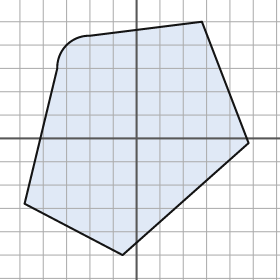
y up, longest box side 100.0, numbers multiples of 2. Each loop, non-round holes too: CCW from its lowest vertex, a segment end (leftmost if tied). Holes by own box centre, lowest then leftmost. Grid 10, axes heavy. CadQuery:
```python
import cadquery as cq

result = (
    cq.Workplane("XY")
    .moveTo(-6.0, -50.0)
    .lineTo(48.0, -2.0)
    .lineTo(28.0, 50.0)
    .lineTo(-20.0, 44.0)
    .threePointArc((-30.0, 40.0), (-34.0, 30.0))
    .lineTo(-48.0, -28.0)
    .close()
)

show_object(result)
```